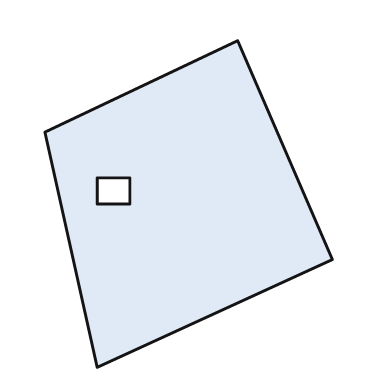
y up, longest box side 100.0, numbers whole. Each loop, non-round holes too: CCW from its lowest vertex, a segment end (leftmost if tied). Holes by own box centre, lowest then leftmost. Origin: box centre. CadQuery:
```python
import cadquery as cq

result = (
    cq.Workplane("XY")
    .moveTo(-28.0, -50.0)
    .lineTo(44.0, -17.0)
    .lineTo(15.0, 50.0)
    .lineTo(-44.0, 22.0)
    .close()
    .moveTo(-28.0, 0.0)
    .lineTo(-18.0, 0.0)
    .lineTo(-18.0, 8.0)
    .lineTo(-28.0, 8.0)
    .close()
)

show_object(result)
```